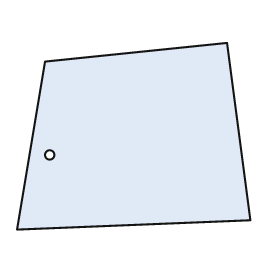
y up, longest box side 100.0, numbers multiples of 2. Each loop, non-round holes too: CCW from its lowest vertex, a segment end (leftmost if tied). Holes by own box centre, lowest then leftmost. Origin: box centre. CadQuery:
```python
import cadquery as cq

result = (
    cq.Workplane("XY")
    .moveTo(-50.0, -40.0)
    .lineTo(50.0, -36.0)
    .lineTo(40.0, 40.0)
    .lineTo(-38.0, 32.0)
    .close()
    .moveTo(-36.0, -8.0)
    .circle(2.0)
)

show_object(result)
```